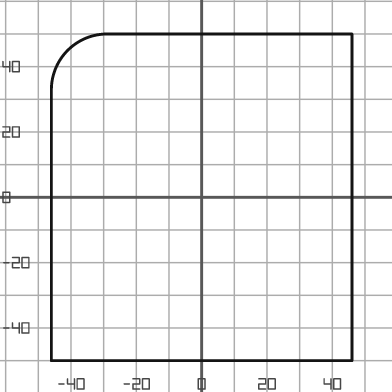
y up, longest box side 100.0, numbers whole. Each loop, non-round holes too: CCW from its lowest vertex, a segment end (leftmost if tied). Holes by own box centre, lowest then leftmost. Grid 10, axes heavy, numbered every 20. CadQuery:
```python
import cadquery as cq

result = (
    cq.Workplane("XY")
    .moveTo(-46.0, -50.0)
    .lineTo(46.0, -50.0)
    .lineTo(46.0, 50.0)
    .lineTo(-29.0, 50.0)
    .threePointArc((-41.0, 45.0), (-46.0, 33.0))
    .close()
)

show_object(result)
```